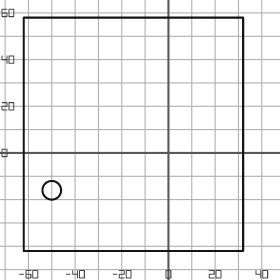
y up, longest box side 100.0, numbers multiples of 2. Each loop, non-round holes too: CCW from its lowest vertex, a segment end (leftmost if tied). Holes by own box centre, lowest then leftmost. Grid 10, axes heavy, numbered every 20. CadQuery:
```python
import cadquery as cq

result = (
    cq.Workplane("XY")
    .moveTo(-62.0, -42.0)
    .lineTo(32.0, -42.0)
    .lineTo(32.0, 58.0)
    .lineTo(-62.0, 58.0)
    .close()
    .moveTo(-50.0, -16.0)
    .circle(4.0)
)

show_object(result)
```